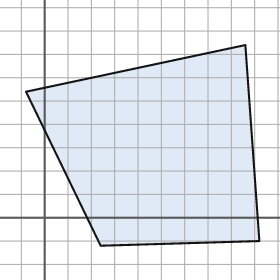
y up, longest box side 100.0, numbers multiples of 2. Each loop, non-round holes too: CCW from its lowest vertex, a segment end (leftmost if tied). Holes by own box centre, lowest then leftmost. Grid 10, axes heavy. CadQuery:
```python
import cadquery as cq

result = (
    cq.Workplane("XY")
    .moveTo(24.0, -12.0)
    .lineTo(92.0, -10.0)
    .lineTo(86.0, 74.0)
    .lineTo(-8.0, 54.0)
    .close()
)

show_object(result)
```